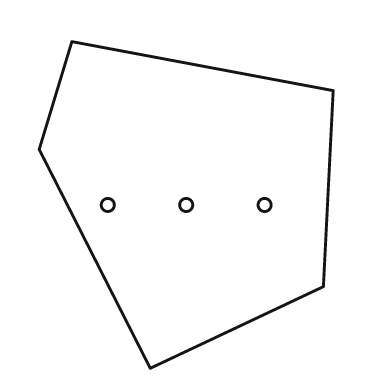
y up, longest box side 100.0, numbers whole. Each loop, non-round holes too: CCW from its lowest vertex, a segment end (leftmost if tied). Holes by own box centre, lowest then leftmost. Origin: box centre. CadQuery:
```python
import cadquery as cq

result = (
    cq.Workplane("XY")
    .moveTo(-11.0, -50.0)
    .lineTo(42.0, -25.0)
    .lineTo(45.0, 35.0)
    .lineTo(-35.0, 50.0)
    .lineTo(-45.0, 17.0)
    .close()
    .moveTo(-24.0, 0.0)
    .circle(2.0)
    .moveTo(0.0, 0.0)
    .circle(2.0)
    .moveTo(24.0, 0.0)
    .circle(2.0)
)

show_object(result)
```